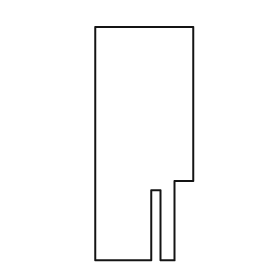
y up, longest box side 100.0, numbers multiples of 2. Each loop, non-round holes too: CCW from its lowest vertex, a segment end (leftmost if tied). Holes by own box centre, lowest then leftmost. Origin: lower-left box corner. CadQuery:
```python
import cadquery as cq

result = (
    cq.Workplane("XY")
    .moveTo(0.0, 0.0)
    .lineTo(24.0, 0.0)
    .lineTo(24.0, 30.0)
    .lineTo(28.0, 30.0)
    .lineTo(28.0, 0.0)
    .lineTo(34.0, 0.0)
    .lineTo(34.0, 34.0)
    .lineTo(42.0, 34.0)
    .lineTo(42.0, 100.0)
    .lineTo(0.0, 100.0)
    .close()
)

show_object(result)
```